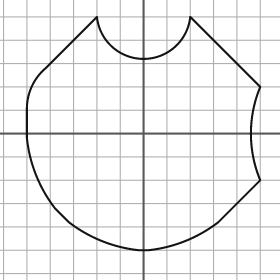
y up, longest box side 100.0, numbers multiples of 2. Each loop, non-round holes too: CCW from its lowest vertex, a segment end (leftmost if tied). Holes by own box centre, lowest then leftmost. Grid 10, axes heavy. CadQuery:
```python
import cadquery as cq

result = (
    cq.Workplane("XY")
    .moveTo(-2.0, -50.0)
    .lineTo(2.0, -50.0)
    .threePointArc((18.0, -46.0), (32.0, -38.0))
    .lineTo(50.0, -20.0)
    .threePointArc((46.0, 0.0), (50.0, 20.0))
    .lineTo(20.0, 50.0)
    .threePointArc((0.0, 32.0), (-20.0, 50.0))
    .lineTo(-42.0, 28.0)
    .threePointArc((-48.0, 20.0), (-50.0, 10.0))
    .lineTo(-50.0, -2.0)
    .threePointArc((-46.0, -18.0), (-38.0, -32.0))
    .lineTo(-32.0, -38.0)
    .threePointArc((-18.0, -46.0), (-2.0, -50.0))
    .close()
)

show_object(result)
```